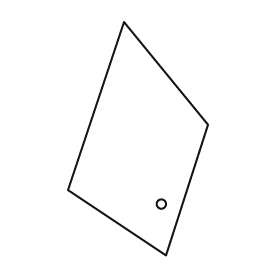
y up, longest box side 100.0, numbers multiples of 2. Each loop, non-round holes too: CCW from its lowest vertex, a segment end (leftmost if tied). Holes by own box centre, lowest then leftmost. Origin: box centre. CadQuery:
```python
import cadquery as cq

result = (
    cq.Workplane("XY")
    .moveTo(12.0, -50.0)
    .lineTo(30.0, 6.0)
    .lineTo(-6.0, 50.0)
    .lineTo(-30.0, -22.0)
    .close()
    .moveTo(10.0, -28.0)
    .circle(2.0)
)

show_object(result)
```